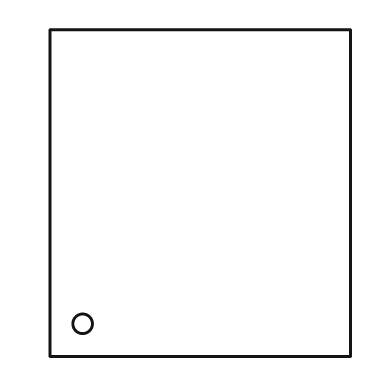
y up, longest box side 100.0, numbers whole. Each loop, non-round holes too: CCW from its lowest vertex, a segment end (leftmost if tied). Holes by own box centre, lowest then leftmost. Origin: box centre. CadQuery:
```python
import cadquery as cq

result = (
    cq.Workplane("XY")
    .moveTo(-46.0, -50.0)
    .lineTo(46.0, -50.0)
    .lineTo(46.0, 50.0)
    .lineTo(-46.0, 50.0)
    .close()
    .moveTo(-36.0, -40.0)
    .circle(3.0)
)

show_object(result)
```